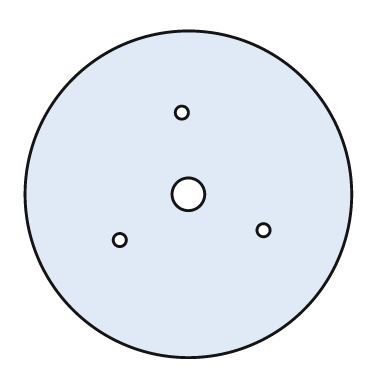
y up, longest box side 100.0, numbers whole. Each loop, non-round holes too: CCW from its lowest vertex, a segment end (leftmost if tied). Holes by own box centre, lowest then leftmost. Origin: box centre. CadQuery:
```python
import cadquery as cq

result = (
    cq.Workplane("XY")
    .moveTo(0.0, 0.0)
    .circle(50.0)
    .moveTo(-21.0, -14.0)
    .circle(2.0)
    .moveTo(23.0, -11.0)
    .circle(2.0)
    .moveTo(0.0, 0.0)
    .circle(5.0)
    .moveTo(-2.0, 25.0)
    .circle(2.0)
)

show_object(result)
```